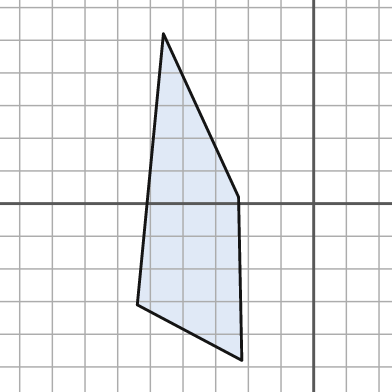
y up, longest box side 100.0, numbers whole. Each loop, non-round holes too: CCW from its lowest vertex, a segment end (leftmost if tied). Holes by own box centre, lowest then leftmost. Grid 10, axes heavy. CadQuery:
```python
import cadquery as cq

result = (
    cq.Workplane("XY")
    .moveTo(-22.0, -48.0)
    .lineTo(-23.0, 2.0)
    .lineTo(-46.0, 52.0)
    .lineTo(-54.0, -31.0)
    .close()
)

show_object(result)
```